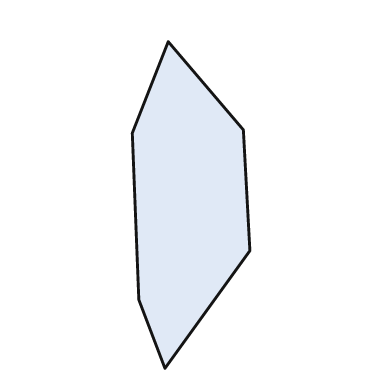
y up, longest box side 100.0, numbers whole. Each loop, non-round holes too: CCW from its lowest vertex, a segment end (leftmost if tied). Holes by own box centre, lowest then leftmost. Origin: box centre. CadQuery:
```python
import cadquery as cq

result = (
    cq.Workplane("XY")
    .moveTo(-8.0, -50.0)
    .lineTo(18.0, -14.0)
    .lineTo(16.0, 23.0)
    .lineTo(-7.0, 50.0)
    .lineTo(-18.0, 22.0)
    .lineTo(-16.0, -29.0)
    .close()
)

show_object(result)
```